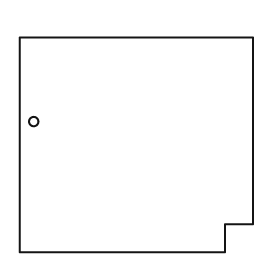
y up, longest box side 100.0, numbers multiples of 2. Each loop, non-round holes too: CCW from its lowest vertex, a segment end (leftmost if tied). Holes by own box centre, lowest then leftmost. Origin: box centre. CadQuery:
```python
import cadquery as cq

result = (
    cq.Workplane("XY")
    .moveTo(-50.0, -46.0)
    .lineTo(38.0, -46.0)
    .lineTo(38.0, -34.0)
    .lineTo(50.0, -34.0)
    .lineTo(50.0, 46.0)
    .lineTo(-50.0, 46.0)
    .close()
    .moveTo(-44.0, 10.0)
    .circle(2.0)
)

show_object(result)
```